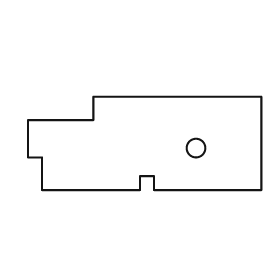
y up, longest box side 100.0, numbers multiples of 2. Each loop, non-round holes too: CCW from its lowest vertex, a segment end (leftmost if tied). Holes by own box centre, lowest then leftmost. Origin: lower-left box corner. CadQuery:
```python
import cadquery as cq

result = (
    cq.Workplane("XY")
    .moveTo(6.0, 0.0)
    .lineTo(48.0, 0.0)
    .lineTo(48.0, 6.0)
    .lineTo(54.0, 6.0)
    .lineTo(54.0, 0.0)
    .lineTo(100.0, 0.0)
    .lineTo(100.0, 40.0)
    .lineTo(28.0, 40.0)
    .lineTo(28.0, 30.0)
    .lineTo(0.0, 30.0)
    .lineTo(0.0, 14.0)
    .lineTo(6.0, 14.0)
    .close()
    .moveTo(72.0, 18.0)
    .circle(4.0)
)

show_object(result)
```